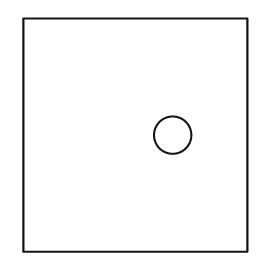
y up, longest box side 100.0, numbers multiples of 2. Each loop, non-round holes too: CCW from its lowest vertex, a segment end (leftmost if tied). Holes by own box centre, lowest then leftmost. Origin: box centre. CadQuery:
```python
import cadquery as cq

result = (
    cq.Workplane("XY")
    .moveTo(-48.0, -50.0)
    .lineTo(48.0, -50.0)
    .lineTo(48.0, 50.0)
    .lineTo(-48.0, 50.0)
    .close()
    .moveTo(16.0, 0.0)
    .circle(8.0)
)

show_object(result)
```